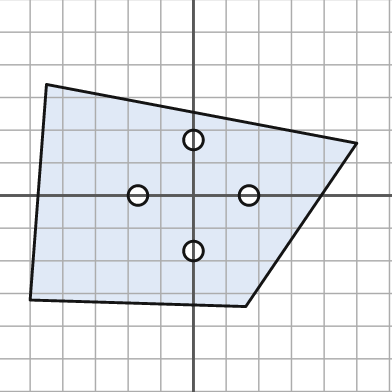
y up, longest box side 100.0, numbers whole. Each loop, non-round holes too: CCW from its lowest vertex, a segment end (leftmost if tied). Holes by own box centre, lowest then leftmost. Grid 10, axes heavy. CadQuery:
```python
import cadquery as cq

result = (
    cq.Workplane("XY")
    .moveTo(16.0, -34.0)
    .lineTo(50.0, 16.0)
    .lineTo(-45.0, 34.0)
    .lineTo(-50.0, -32.0)
    .close()
    .moveTo(0.0, -17.0)
    .circle(3.0)
    .moveTo(-17.0, 0.0)
    .circle(3.0)
    .moveTo(17.0, 0.0)
    .circle(3.0)
    .moveTo(0.0, 17.0)
    .circle(3.0)
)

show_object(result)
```